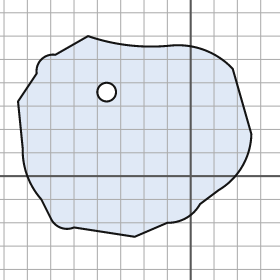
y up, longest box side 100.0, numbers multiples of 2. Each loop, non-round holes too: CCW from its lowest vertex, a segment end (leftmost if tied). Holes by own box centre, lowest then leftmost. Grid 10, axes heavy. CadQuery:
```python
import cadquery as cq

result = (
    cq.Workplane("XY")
    .moveTo(-24.0, -26.0)
    .lineTo(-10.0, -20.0)
    .threePointArc((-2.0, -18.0), (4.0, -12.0))
    .lineTo(12.0, -6.0)
    .threePointArc((22.0, 4.0), (26.0, 18.0))
    .lineTo(18.0, 46.0)
    .threePointArc((6.0, 54.0), (-8.0, 56.0))
    .threePointArc((-26.0, 56.0), (-44.0, 60.0))
    .lineTo(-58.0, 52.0)
    .threePointArc((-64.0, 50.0), (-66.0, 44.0))
    .lineTo(-74.0, 32.0)
    .lineTo(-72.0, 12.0)
    .threePointArc((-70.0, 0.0), (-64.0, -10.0))
    .lineTo(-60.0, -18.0)
    .threePointArc((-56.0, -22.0), (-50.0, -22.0))
    .close()
    .moveTo(-36.0, 36.0)
    .circle(4.0)
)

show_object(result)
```